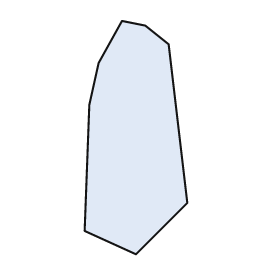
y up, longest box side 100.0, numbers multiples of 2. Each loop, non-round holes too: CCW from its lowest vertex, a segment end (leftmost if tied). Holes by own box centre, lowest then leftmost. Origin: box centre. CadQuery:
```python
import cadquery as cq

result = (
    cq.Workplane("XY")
    .moveTo(0.0, -50.0)
    .lineTo(22.0, -28.0)
    .lineTo(14.0, 40.0)
    .lineTo(4.0, 48.0)
    .lineTo(-6.0, 50.0)
    .lineTo(-16.0, 32.0)
    .lineTo(-20.0, 14.0)
    .lineTo(-22.0, -40.0)
    .close()
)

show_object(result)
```